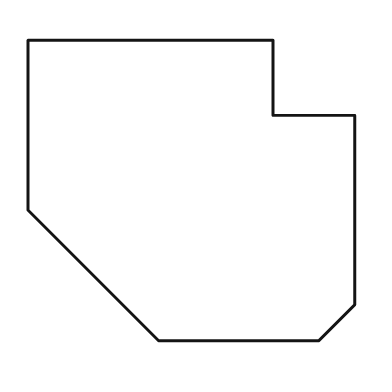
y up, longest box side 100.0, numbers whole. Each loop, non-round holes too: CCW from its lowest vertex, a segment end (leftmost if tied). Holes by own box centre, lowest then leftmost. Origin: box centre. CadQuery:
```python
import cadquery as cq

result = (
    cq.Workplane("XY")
    .moveTo(-10.0, -46.0)
    .lineTo(39.0, -46.0)
    .lineTo(50.0, -35.0)
    .lineTo(50.0, 23.0)
    .lineTo(25.0, 23.0)
    .lineTo(25.0, 46.0)
    .lineTo(-50.0, 46.0)
    .lineTo(-50.0, -6.0)
    .close()
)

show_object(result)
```